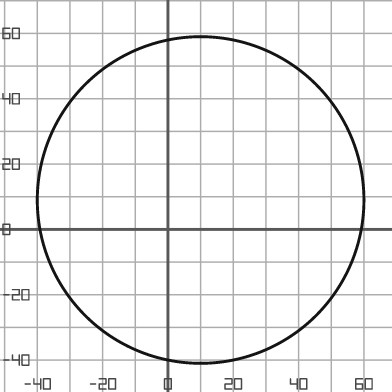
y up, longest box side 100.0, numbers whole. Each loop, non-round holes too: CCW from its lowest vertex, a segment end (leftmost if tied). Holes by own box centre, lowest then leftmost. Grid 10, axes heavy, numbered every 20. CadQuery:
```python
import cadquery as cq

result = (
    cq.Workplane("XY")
    .moveTo(10.0, 9.0)
    .circle(50.0)
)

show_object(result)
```